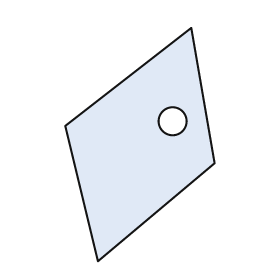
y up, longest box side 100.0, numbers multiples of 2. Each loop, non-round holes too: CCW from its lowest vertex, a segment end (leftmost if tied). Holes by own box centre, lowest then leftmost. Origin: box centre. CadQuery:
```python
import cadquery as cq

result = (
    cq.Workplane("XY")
    .moveTo(-18.0, -50.0)
    .lineTo(32.0, -8.0)
    .lineTo(22.0, 50.0)
    .lineTo(-32.0, 8.0)
    .close()
    .moveTo(14.0, 10.0)
    .circle(6.0)
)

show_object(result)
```